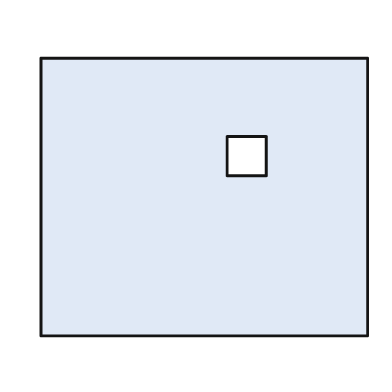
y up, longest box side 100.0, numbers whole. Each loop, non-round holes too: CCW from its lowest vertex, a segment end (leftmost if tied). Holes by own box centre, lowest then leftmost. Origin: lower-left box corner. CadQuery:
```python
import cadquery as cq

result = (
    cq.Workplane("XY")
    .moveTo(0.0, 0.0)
    .lineTo(100.0, 0.0)
    .lineTo(100.0, 85.0)
    .lineTo(0.0, 85.0)
    .close()
    .moveTo(57.0, 49.0)
    .lineTo(69.0, 49.0)
    .lineTo(69.0, 61.0)
    .lineTo(57.0, 61.0)
    .close()
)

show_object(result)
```